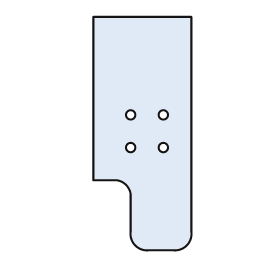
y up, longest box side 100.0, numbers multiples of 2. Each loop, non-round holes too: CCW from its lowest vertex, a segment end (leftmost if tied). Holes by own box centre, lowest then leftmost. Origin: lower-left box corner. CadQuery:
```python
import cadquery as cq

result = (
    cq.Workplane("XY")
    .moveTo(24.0, 0.0)
    .lineTo(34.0, 0.0)
    .threePointArc((40.0, 2.0), (42.0, 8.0))
    .lineTo(42.0, 100.0)
    .lineTo(0.0, 100.0)
    .lineTo(0.0, 30.0)
    .lineTo(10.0, 30.0)
    .threePointArc((14.0, 28.0), (16.0, 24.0))
    .lineTo(16.0, 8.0)
    .threePointArc((18.0, 2.0), (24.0, 0.0))
    .close()
    .moveTo(16.0, 44.0)
    .circle(2.0)
    .moveTo(30.0, 44.0)
    .circle(2.0)
    .moveTo(16.0, 58.0)
    .circle(2.0)
    .moveTo(30.0, 58.0)
    .circle(2.0)
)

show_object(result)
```